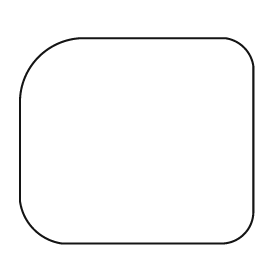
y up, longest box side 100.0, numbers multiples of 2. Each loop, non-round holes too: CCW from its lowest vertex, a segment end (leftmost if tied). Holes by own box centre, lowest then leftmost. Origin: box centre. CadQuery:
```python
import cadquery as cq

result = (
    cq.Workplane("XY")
    .moveTo(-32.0, -44.0)
    .lineTo(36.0, -44.0)
    .threePointArc((46.0, -40.0), (50.0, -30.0))
    .lineTo(50.0, 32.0)
    .threePointArc((46.0, 40.0), (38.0, 44.0))
    .lineTo(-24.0, 44.0)
    .threePointArc((-42.0, 36.0), (-50.0, 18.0))
    .lineTo(-50.0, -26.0)
    .threePointArc((-44.0, -38.0), (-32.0, -44.0))
    .close()
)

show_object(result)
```